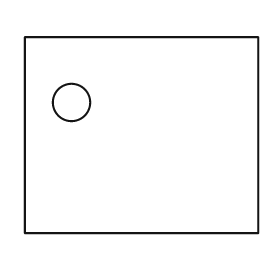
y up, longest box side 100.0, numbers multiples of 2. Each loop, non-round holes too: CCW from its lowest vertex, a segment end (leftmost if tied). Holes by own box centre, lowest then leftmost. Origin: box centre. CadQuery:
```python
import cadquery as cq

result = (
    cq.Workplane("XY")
    .moveTo(-50.0, -42.0)
    .lineTo(50.0, -42.0)
    .lineTo(50.0, 42.0)
    .lineTo(-50.0, 42.0)
    .close()
    .moveTo(-30.0, 14.0)
    .circle(8.0)
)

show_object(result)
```